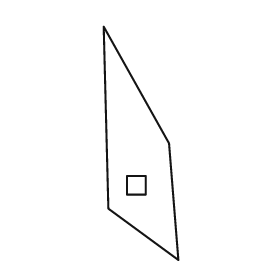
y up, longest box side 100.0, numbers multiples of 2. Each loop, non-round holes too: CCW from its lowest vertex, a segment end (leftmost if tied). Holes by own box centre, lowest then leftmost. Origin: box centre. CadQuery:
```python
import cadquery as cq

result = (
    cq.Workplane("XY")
    .moveTo(16.0, -50.0)
    .lineTo(12.0, 0.0)
    .lineTo(-16.0, 50.0)
    .lineTo(-14.0, -28.0)
    .close()
    .moveTo(-6.0, -22.0)
    .lineTo(2.0, -22.0)
    .lineTo(2.0, -14.0)
    .lineTo(-6.0, -14.0)
    .close()
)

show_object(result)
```